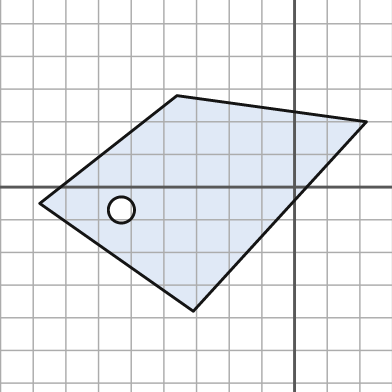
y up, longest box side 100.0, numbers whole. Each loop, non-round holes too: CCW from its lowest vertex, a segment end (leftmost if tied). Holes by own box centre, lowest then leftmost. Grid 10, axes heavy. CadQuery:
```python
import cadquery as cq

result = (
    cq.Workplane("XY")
    .moveTo(-31.0, -38.0)
    .lineTo(22.0, 20.0)
    .lineTo(-36.0, 28.0)
    .lineTo(-78.0, -5.0)
    .close()
    .moveTo(-53.0, -7.0)
    .circle(4.0)
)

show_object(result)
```